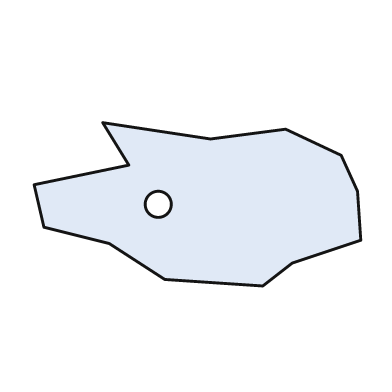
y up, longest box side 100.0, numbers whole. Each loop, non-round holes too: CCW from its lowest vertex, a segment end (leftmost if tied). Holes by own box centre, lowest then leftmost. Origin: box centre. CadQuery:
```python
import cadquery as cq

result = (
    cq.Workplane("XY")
    .moveTo(20.0, -25.0)
    .lineTo(29.0, -18.0)
    .lineTo(50.0, -11.0)
    .lineTo(49.0, 4.0)
    .lineTo(44.0, 15.0)
    .lineTo(27.0, 23.0)
    .lineTo(4.0, 20.0)
    .lineTo(-29.0, 25.0)
    .lineTo(-21.0, 12.0)
    .lineTo(-50.0, 6.0)
    .lineTo(-47.0, -7.0)
    .lineTo(-27.0, -12.0)
    .lineTo(-10.0, -23.0)
    .close()
    .moveTo(-12.0, 0.0)
    .circle(4.0)
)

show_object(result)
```